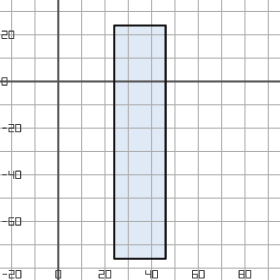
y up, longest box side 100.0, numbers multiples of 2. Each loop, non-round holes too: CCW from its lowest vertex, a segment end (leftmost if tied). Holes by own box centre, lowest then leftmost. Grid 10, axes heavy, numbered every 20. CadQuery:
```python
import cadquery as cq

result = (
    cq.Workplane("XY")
    .moveTo(24.0, -76.0)
    .lineTo(46.0, -76.0)
    .lineTo(46.0, 24.0)
    .lineTo(24.0, 24.0)
    .close()
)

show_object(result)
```